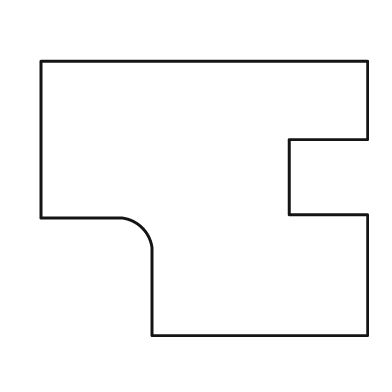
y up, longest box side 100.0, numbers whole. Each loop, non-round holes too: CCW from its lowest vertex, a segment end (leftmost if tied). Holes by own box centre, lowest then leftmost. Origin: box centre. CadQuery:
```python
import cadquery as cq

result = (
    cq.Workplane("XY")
    .moveTo(-16.0, -42.0)
    .lineTo(50.0, -42.0)
    .lineTo(50.0, -5.0)
    .lineTo(26.0, -5.0)
    .lineTo(26.0, 18.0)
    .lineTo(50.0, 18.0)
    .lineTo(50.0, 42.0)
    .lineTo(-50.0, 42.0)
    .lineTo(-50.0, -6.0)
    .lineTo(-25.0, -6.0)
    .threePointArc((-19.0, -9.0), (-16.0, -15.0))
    .close()
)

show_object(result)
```